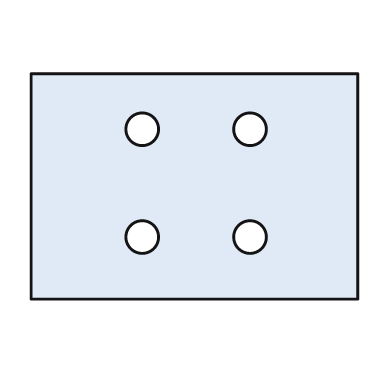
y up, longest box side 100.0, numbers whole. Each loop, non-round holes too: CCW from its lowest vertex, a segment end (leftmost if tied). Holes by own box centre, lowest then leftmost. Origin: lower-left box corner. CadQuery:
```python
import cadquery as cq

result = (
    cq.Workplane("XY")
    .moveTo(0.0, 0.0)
    .lineTo(100.0, 0.0)
    .lineTo(100.0, 69.0)
    .lineTo(0.0, 69.0)
    .close()
    .moveTo(34.0, 19.0)
    .circle(5.0)
    .moveTo(67.0, 19.0)
    .circle(5.0)
    .moveTo(34.0, 52.0)
    .circle(5.0)
    .moveTo(67.0, 52.0)
    .circle(5.0)
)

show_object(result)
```